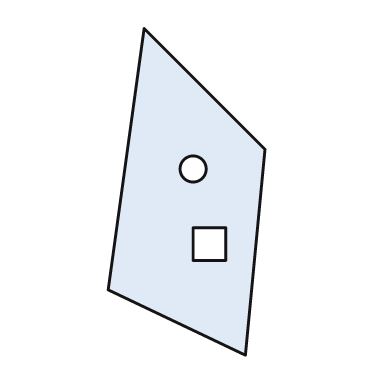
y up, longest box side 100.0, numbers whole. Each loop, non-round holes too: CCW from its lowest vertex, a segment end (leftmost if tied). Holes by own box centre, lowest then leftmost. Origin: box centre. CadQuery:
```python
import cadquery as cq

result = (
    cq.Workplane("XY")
    .moveTo(18.0, -50.0)
    .lineTo(24.0, 13.0)
    .lineTo(-13.0, 50.0)
    .lineTo(-24.0, -30.0)
    .close()
    .moveTo(2.0, -21.0)
    .lineTo(12.0, -21.0)
    .lineTo(12.0, -11.0)
    .lineTo(2.0, -11.0)
    .close()
    .moveTo(2.0, 7.0)
    .circle(4.0)
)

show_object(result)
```